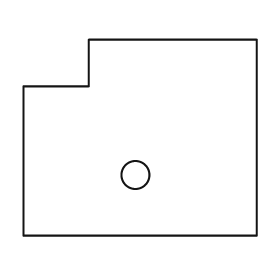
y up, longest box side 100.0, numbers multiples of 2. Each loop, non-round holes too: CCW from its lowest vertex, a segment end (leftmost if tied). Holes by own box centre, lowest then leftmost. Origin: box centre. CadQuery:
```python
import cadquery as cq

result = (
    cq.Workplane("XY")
    .moveTo(-50.0, -42.0)
    .lineTo(50.0, -42.0)
    .lineTo(50.0, 42.0)
    .lineTo(-22.0, 42.0)
    .lineTo(-22.0, 22.0)
    .lineTo(-50.0, 22.0)
    .close()
    .moveTo(-2.0, -16.0)
    .circle(6.0)
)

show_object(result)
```